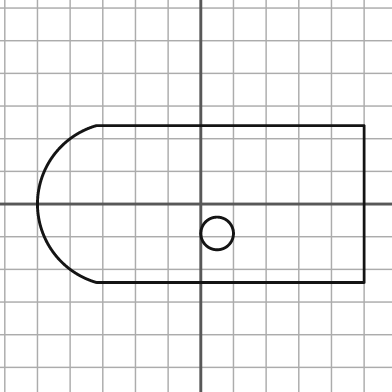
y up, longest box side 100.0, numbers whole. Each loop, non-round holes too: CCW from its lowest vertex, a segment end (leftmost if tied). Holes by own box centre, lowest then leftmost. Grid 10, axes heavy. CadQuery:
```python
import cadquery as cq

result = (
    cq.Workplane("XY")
    .moveTo(-32.0, -24.0)
    .lineTo(50.0, -24.0)
    .lineTo(50.0, 24.0)
    .lineTo(-32.0, 24.0)
    .threePointArc((-50.0, 0.0), (-32.0, -24.0))
    .close()
    .moveTo(5.0, -9.0)
    .circle(5.0)
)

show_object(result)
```